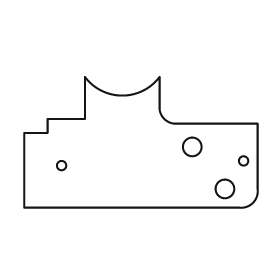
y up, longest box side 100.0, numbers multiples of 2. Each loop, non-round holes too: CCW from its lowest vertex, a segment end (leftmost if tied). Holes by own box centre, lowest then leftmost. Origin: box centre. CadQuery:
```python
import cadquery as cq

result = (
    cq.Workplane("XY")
    .moveTo(-50.0, -28.0)
    .lineTo(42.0, -28.0)
    .threePointArc((48.0, -26.0), (50.0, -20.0))
    .lineTo(50.0, 8.0)
    .lineTo(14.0, 8.0)
    .threePointArc((10.0, 10.0), (8.0, 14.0))
    .lineTo(8.0, 28.0)
    .threePointArc((-8.0, 20.0), (-24.0, 28.0))
    .lineTo(-24.0, 10.0)
    .lineTo(-40.0, 10.0)
    .lineTo(-40.0, 4.0)
    .lineTo(-50.0, 4.0)
    .close()
    .moveTo(36.0, -20.0)
    .circle(4.0)
    .moveTo(-34.0, -10.0)
    .circle(2.0)
    .moveTo(44.0, -8.0)
    .circle(2.0)
    .moveTo(22.0, -2.0)
    .circle(4.0)
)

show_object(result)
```